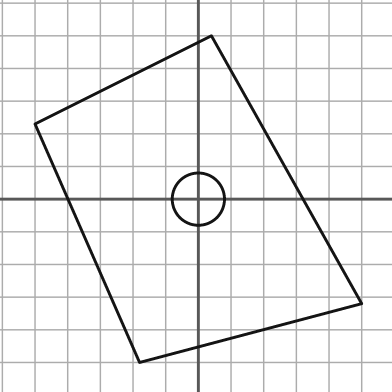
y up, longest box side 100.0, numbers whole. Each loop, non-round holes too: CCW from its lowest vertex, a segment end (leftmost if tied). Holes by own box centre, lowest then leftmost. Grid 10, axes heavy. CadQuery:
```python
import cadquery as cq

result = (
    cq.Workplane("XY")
    .moveTo(-18.0, -50.0)
    .lineTo(50.0, -32.0)
    .lineTo(4.0, 50.0)
    .lineTo(-50.0, 23.0)
    .close()
    .moveTo(0.0, 0.0)
    .circle(8.0)
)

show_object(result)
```